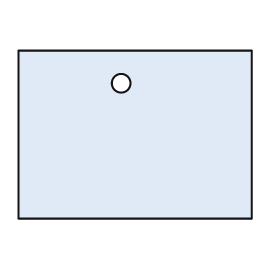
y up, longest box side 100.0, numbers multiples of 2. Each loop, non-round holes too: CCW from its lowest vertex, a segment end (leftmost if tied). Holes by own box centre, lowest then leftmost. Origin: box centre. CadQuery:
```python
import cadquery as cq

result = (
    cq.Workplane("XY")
    .moveTo(-50.0, -36.0)
    .lineTo(50.0, -36.0)
    .lineTo(50.0, 36.0)
    .lineTo(-50.0, 36.0)
    .close()
    .moveTo(-6.0, 22.0)
    .circle(4.0)
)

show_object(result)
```